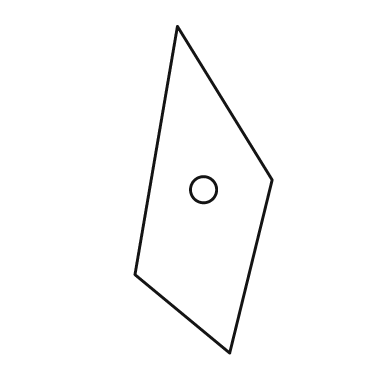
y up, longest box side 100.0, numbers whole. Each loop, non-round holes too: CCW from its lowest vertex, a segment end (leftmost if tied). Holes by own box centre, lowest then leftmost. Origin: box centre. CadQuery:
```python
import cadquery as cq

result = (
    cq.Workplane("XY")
    .moveTo(8.0, -50.0)
    .lineTo(21.0, 3.0)
    .lineTo(-8.0, 50.0)
    .lineTo(-21.0, -26.0)
    .close()
    .moveTo(0.0, 0.0)
    .circle(4.0)
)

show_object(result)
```